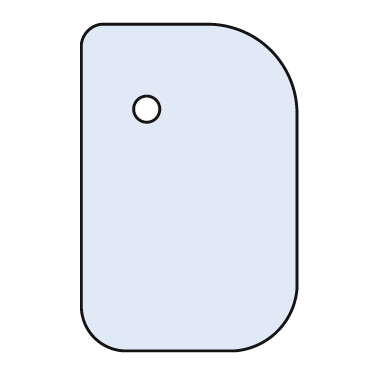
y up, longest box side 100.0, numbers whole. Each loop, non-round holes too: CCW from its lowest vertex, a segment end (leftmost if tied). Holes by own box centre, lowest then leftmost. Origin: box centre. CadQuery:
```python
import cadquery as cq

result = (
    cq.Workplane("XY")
    .moveTo(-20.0, -50.0)
    .lineTo(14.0, -50.0)
    .threePointArc((27.0, -44.0), (33.0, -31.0))
    .lineTo(33.0, 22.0)
    .threePointArc((25.0, 42.0), (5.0, 50.0))
    .lineTo(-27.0, 50.0)
    .threePointArc((-31.0, 48.0), (-33.0, 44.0))
    .lineTo(-33.0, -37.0)
    .threePointArc((-29.0, -46.0), (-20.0, -50.0))
    .close()
    .moveTo(-13.0, 24.0)
    .circle(4.0)
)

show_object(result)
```